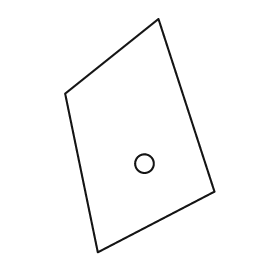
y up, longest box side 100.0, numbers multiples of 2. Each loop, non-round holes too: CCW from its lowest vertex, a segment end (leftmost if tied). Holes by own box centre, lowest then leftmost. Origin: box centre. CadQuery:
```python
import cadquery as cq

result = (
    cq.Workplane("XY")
    .moveTo(-18.0, -50.0)
    .lineTo(32.0, -24.0)
    .lineTo(8.0, 50.0)
    .lineTo(-32.0, 18.0)
    .close()
    .moveTo(2.0, -12.0)
    .circle(4.0)
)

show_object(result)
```